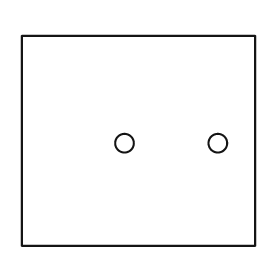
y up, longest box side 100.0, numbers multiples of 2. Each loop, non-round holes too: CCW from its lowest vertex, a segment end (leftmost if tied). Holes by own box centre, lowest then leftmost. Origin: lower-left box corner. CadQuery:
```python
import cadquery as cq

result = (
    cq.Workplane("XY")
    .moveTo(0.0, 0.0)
    .lineTo(100.0, 0.0)
    .lineTo(100.0, 90.0)
    .lineTo(0.0, 90.0)
    .close()
    .moveTo(44.0, 44.0)
    .circle(4.0)
    .moveTo(84.0, 44.0)
    .circle(4.0)
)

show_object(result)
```